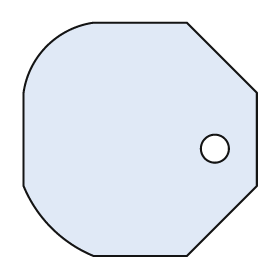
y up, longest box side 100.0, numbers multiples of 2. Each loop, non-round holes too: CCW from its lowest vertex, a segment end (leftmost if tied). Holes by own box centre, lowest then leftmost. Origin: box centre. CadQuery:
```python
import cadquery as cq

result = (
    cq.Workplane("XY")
    .moveTo(-20.0, -50.0)
    .lineTo(20.0, -50.0)
    .lineTo(50.0, -20.0)
    .lineTo(50.0, 20.0)
    .lineTo(20.0, 50.0)
    .lineTo(-20.0, 50.0)
    .threePointArc((-40.0, 40.0), (-50.0, 20.0))
    .lineTo(-50.0, -20.0)
    .threePointArc((-38.0, -38.0), (-20.0, -50.0))
    .close()
    .moveTo(32.0, -4.0)
    .circle(6.0)
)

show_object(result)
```